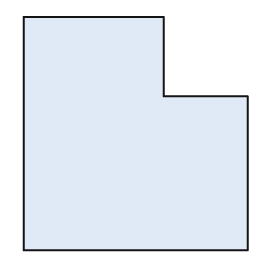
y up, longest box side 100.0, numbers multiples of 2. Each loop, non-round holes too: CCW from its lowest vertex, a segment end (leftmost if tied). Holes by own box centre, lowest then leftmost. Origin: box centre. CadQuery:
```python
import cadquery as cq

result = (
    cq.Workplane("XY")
    .moveTo(-48.0, -50.0)
    .lineTo(48.0, -50.0)
    .lineTo(48.0, 16.0)
    .lineTo(12.0, 16.0)
    .lineTo(12.0, 50.0)
    .lineTo(-48.0, 50.0)
    .close()
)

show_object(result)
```